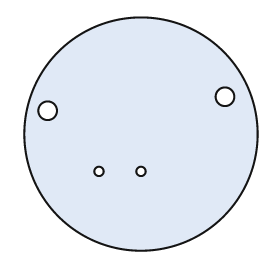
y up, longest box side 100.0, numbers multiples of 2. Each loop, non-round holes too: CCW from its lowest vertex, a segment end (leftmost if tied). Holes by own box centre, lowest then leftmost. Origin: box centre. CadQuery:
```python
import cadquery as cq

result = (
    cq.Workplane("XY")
    .moveTo(0.0, 0.0)
    .circle(50.0)
    .moveTo(-18.0, -16.0)
    .circle(2.0)
    .moveTo(0.0, -16.0)
    .circle(2.0)
    .moveTo(-40.0, 10.0)
    .circle(4.0)
    .moveTo(36.0, 16.0)
    .circle(4.0)
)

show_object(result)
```